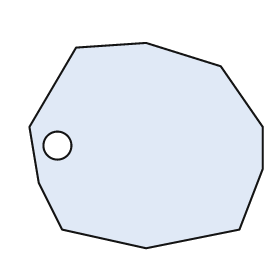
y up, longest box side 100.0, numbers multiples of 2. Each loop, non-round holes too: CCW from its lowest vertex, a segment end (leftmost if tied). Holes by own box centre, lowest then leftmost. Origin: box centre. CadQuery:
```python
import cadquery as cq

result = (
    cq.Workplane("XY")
    .moveTo(0.0, -44.0)
    .lineTo(40.0, -36.0)
    .lineTo(50.0, -10.0)
    .lineTo(50.0, 8.0)
    .lineTo(32.0, 34.0)
    .lineTo(0.0, 44.0)
    .lineTo(-30.0, 42.0)
    .lineTo(-50.0, 8.0)
    .lineTo(-46.0, -16.0)
    .lineTo(-36.0, -36.0)
    .close()
    .moveTo(-38.0, 0.0)
    .circle(6.0)
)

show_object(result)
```